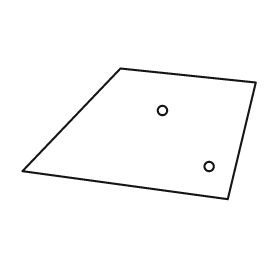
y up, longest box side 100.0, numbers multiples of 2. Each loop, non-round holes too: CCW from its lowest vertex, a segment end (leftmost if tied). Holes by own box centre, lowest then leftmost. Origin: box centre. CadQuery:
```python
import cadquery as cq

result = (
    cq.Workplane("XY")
    .moveTo(38.0, -28.0)
    .lineTo(50.0, 22.0)
    .lineTo(-8.0, 28.0)
    .lineTo(-50.0, -16.0)
    .close()
    .moveTo(30.0, -14.0)
    .circle(2.0)
    .moveTo(10.0, 10.0)
    .circle(2.0)
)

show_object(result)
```